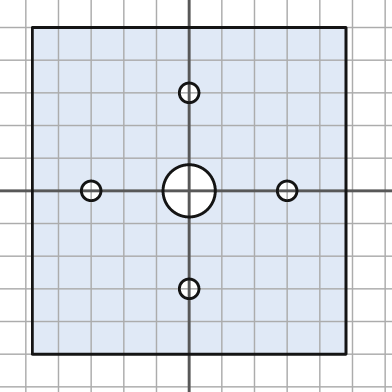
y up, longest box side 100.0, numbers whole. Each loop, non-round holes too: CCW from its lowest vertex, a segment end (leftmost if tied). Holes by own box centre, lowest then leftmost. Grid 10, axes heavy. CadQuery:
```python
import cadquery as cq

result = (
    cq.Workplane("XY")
    .moveTo(-48.0, -50.0)
    .lineTo(48.0, -50.0)
    .lineTo(48.0, 50.0)
    .lineTo(-48.0, 50.0)
    .close()
    .moveTo(0.0, -30.0)
    .circle(3.0)
    .moveTo(-30.0, 0.0)
    .circle(3.0)
    .moveTo(0.0, 0.0)
    .circle(8.0)
    .moveTo(30.0, 0.0)
    .circle(3.0)
    .moveTo(0.0, 30.0)
    .circle(3.0)
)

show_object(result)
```